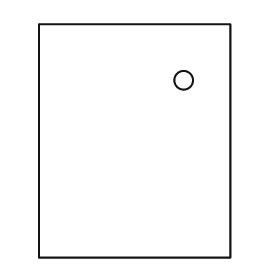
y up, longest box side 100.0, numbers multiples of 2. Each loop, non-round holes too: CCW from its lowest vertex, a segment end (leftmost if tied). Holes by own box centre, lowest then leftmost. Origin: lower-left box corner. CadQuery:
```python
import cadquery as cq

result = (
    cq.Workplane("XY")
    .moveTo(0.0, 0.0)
    .lineTo(82.0, 0.0)
    .lineTo(82.0, 100.0)
    .lineTo(0.0, 100.0)
    .close()
    .moveTo(62.0, 76.0)
    .circle(4.0)
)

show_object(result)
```